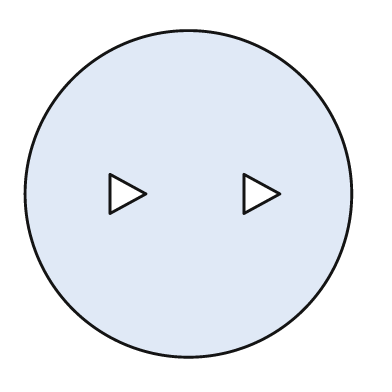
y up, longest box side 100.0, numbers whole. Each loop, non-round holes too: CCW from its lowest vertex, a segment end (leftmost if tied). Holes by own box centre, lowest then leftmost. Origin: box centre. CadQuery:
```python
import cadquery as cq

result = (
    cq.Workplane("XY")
    .moveTo(0.0, 0.0)
    .circle(50.0)
    .moveTo(-24.0, -6.0)
    .lineTo(-13.0, 0.0)
    .lineTo(-24.0, 6.0)
    .close()
    .moveTo(17.0, -6.0)
    .lineTo(28.0, 0.0)
    .lineTo(17.0, 6.0)
    .close()
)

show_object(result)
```